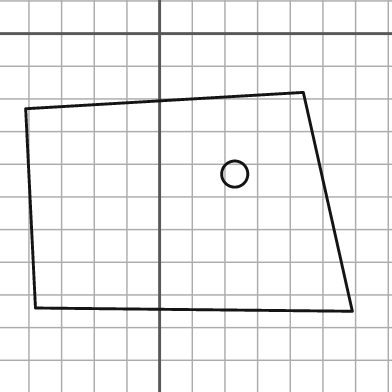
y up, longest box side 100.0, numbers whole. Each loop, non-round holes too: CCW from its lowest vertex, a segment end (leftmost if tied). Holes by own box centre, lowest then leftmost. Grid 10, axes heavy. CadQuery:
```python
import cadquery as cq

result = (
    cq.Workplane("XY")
    .moveTo(59.0, -85.0)
    .lineTo(44.0, -18.0)
    .lineTo(-41.0, -23.0)
    .lineTo(-38.0, -84.0)
    .close()
    .moveTo(23.0, -43.0)
    .circle(4.0)
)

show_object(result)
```